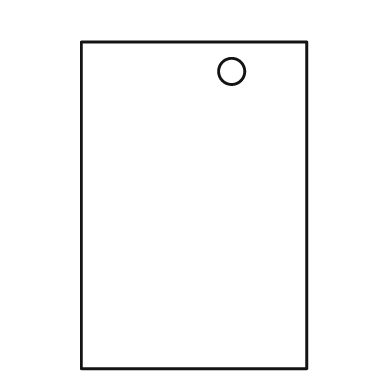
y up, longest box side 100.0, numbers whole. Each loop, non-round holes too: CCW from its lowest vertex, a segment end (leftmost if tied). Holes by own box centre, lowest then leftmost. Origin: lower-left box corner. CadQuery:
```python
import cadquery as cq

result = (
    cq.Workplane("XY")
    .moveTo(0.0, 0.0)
    .lineTo(69.0, 0.0)
    .lineTo(69.0, 100.0)
    .lineTo(0.0, 100.0)
    .close()
    .moveTo(46.0, 91.0)
    .circle(4.0)
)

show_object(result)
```